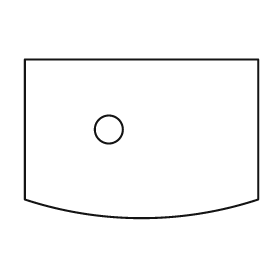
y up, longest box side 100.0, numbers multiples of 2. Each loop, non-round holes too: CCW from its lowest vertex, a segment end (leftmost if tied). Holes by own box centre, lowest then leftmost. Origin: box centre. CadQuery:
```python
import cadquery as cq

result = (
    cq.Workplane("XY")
    .moveTo(-50.0, -26.0)
    .threePointArc((0.0, -34.0), (50.0, -26.0))
    .lineTo(50.0, 34.0)
    .lineTo(-50.0, 34.0)
    .close()
    .moveTo(-14.0, 4.0)
    .circle(6.0)
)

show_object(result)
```